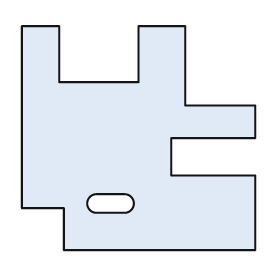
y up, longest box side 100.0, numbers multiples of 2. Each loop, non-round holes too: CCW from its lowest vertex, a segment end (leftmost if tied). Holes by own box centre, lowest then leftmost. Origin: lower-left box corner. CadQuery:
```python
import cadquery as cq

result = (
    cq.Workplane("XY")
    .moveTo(18.0, 0.0)
    .lineTo(100.0, 0.0)
    .lineTo(100.0, 32.0)
    .lineTo(64.0, 32.0)
    .lineTo(64.0, 48.0)
    .lineTo(100.0, 48.0)
    .lineTo(100.0, 62.0)
    .lineTo(70.0, 62.0)
    .lineTo(70.0, 96.0)
    .lineTo(50.0, 96.0)
    .lineTo(50.0, 72.0)
    .lineTo(16.0, 72.0)
    .lineTo(16.0, 96.0)
    .lineTo(0.0, 96.0)
    .lineTo(0.0, 18.0)
    .lineTo(18.0, 18.0)
    .close()
    .moveTo(32.0, 16.0)
    .lineTo(44.0, 16.0)
    .threePointArc((48.0, 20.0), (44.0, 24.0))
    .lineTo(32.0, 24.0)
    .threePointArc((28.0, 20.0), (32.0, 16.0))
    .close()
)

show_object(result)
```